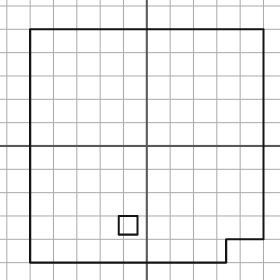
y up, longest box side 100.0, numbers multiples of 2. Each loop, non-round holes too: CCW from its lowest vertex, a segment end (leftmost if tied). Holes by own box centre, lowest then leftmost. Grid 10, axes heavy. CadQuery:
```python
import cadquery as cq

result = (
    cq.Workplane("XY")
    .moveTo(-50.0, -50.0)
    .lineTo(34.0, -50.0)
    .lineTo(34.0, -40.0)
    .lineTo(50.0, -40.0)
    .lineTo(50.0, 50.0)
    .lineTo(-50.0, 50.0)
    .close()
    .moveTo(-12.0, -38.0)
    .lineTo(-4.0, -38.0)
    .lineTo(-4.0, -30.0)
    .lineTo(-12.0, -30.0)
    .close()
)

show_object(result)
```